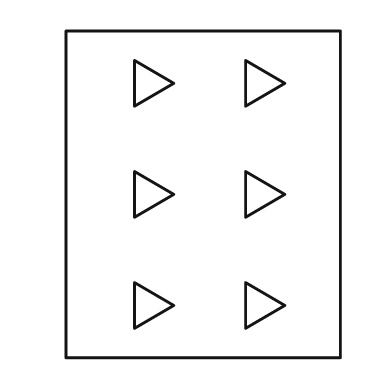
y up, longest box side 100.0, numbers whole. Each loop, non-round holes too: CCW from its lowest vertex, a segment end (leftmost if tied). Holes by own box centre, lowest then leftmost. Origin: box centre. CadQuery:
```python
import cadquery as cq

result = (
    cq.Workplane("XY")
    .moveTo(-42.0, -50.0)
    .lineTo(42.0, -50.0)
    .lineTo(42.0, 50.0)
    .lineTo(-42.0, 50.0)
    .close()
    .moveTo(-21.0, -41.0)
    .lineTo(-9.0, -34.0)
    .lineTo(-21.0, -27.0)
    .close()
    .moveTo(13.0, -41.0)
    .lineTo(25.0, -34.0)
    .lineTo(13.0, -27.0)
    .close()
    .moveTo(-21.0, -7.0)
    .lineTo(-9.0, 0.0)
    .lineTo(-21.0, 7.0)
    .close()
    .moveTo(13.0, -7.0)
    .lineTo(25.0, 0.0)
    .lineTo(13.0, 7.0)
    .close()
    .moveTo(-21.0, 27.0)
    .lineTo(-9.0, 34.0)
    .lineTo(-21.0, 41.0)
    .close()
    .moveTo(13.0, 27.0)
    .lineTo(25.0, 34.0)
    .lineTo(13.0, 41.0)
    .close()
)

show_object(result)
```